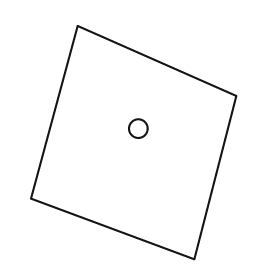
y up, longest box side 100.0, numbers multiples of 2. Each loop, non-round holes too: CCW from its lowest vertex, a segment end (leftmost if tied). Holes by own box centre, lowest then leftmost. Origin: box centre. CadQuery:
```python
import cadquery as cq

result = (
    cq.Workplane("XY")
    .moveTo(26.0, -50.0)
    .lineTo(44.0, 20.0)
    .lineTo(-24.0, 50.0)
    .lineTo(-44.0, -24.0)
    .close()
    .moveTo(2.0, 6.0)
    .circle(4.0)
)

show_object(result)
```